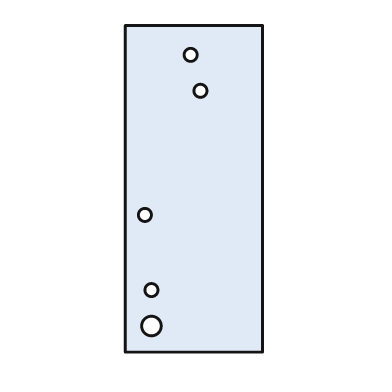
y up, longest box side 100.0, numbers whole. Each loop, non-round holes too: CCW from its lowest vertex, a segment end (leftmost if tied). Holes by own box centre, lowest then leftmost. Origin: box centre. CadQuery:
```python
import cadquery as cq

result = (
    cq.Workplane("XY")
    .moveTo(-21.0, -50.0)
    .lineTo(21.0, -50.0)
    .lineTo(21.0, 50.0)
    .lineTo(-21.0, 50.0)
    .close()
    .moveTo(-13.0, -42.0)
    .circle(3.0)
    .moveTo(-13.0, -31.0)
    .circle(2.0)
    .moveTo(-15.0, -8.0)
    .circle(2.0)
    .moveTo(2.0, 30.0)
    .circle(2.0)
    .moveTo(-1.0, 41.0)
    .circle(2.0)
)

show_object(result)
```